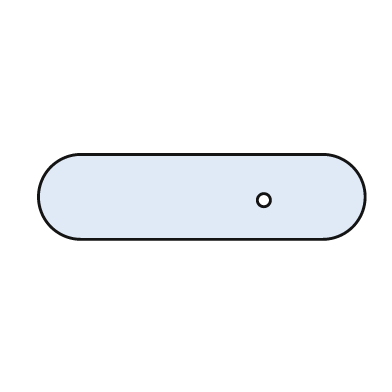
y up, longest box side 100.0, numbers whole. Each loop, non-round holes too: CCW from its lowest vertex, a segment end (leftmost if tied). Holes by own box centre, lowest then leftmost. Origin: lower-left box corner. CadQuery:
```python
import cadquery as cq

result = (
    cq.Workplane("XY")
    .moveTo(13.0, 0.0)
    .lineTo(87.0, 0.0)
    .threePointArc((100.0, 13.0), (87.0, 26.0))
    .lineTo(13.0, 26.0)
    .threePointArc((0.0, 13.0), (13.0, 0.0))
    .close()
    .moveTo(69.0, 12.0)
    .circle(2.0)
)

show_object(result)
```